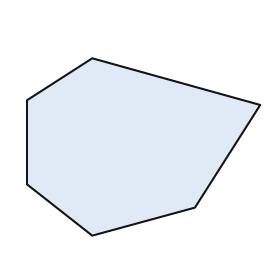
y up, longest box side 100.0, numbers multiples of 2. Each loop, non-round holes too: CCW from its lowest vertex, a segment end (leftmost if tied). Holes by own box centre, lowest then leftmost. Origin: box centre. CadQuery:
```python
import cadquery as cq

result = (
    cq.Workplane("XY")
    .moveTo(-22.0, -38.0)
    .lineTo(22.0, -26.0)
    .lineTo(50.0, 18.0)
    .lineTo(-22.0, 38.0)
    .lineTo(-50.0, 20.0)
    .lineTo(-50.0, -16.0)
    .close()
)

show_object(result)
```